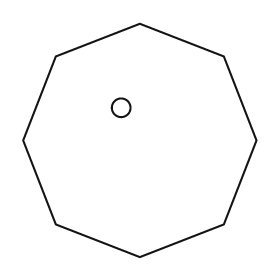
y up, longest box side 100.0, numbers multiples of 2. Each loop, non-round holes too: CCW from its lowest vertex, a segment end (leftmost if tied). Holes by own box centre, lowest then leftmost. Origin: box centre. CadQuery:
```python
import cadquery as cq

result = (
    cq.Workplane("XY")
    .moveTo(0.0, -50.0)
    .lineTo(36.0, -36.0)
    .lineTo(50.0, 0.0)
    .lineTo(36.0, 36.0)
    .lineTo(0.0, 50.0)
    .lineTo(-36.0, 36.0)
    .lineTo(-50.0, 0.0)
    .lineTo(-36.0, -36.0)
    .close()
    .moveTo(-8.0, 14.0)
    .circle(4.0)
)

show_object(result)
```